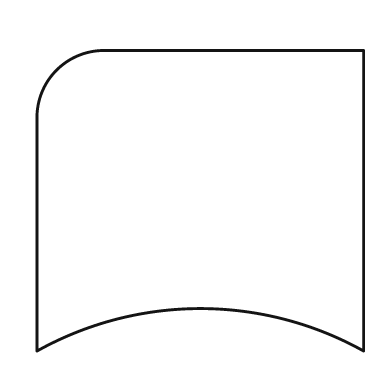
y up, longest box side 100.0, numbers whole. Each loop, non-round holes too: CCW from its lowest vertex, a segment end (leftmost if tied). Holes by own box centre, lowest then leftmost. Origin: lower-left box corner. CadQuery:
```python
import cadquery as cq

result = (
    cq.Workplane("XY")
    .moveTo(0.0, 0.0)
    .threePointArc((50.0, 13.0), (100.0, 0.0))
    .lineTo(100.0, 92.0)
    .lineTo(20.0, 92.0)
    .threePointArc((6.0, 86.0), (0.0, 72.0))
    .close()
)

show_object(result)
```